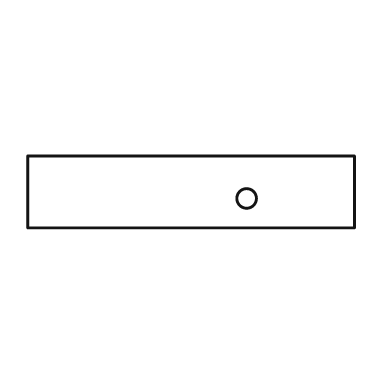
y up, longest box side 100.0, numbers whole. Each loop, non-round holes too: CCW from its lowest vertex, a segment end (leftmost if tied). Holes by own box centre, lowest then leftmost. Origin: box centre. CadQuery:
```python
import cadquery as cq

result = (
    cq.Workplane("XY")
    .moveTo(-50.0, -11.0)
    .lineTo(50.0, -11.0)
    .lineTo(50.0, 11.0)
    .lineTo(-50.0, 11.0)
    .close()
    .moveTo(17.0, -2.0)
    .circle(3.0)
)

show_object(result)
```